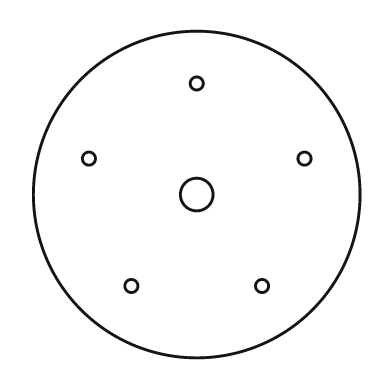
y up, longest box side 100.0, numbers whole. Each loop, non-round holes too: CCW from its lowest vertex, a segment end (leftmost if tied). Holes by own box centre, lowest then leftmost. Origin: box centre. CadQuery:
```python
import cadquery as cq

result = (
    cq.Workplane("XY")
    .moveTo(0.0, 0.0)
    .circle(50.0)
    .moveTo(-20.0, -28.0)
    .circle(2.0)
    .moveTo(20.0, -28.0)
    .circle(2.0)
    .moveTo(0.0, 0.0)
    .circle(5.0)
    .moveTo(-33.0, 11.0)
    .circle(2.0)
    .moveTo(33.0, 11.0)
    .circle(2.0)
    .moveTo(0.0, 34.0)
    .circle(2.0)
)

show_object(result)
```